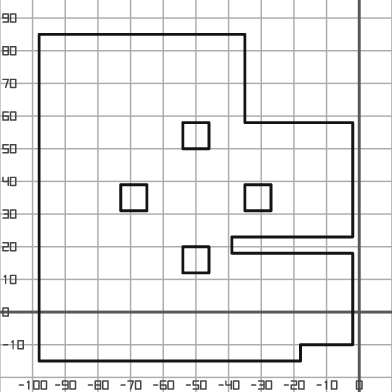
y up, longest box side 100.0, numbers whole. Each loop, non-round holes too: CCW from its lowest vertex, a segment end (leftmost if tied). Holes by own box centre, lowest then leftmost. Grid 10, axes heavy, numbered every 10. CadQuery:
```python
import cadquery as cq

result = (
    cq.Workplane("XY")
    .moveTo(-98.0, -15.0)
    .lineTo(-18.0, -15.0)
    .lineTo(-18.0, -10.0)
    .lineTo(-2.0, -10.0)
    .lineTo(-2.0, 18.0)
    .lineTo(-39.0, 18.0)
    .lineTo(-39.0, 23.0)
    .lineTo(-2.0, 23.0)
    .lineTo(-2.0, 58.0)
    .lineTo(-35.0, 58.0)
    .lineTo(-35.0, 85.0)
    .lineTo(-98.0, 85.0)
    .close()
    .moveTo(-54.0, 12.0)
    .lineTo(-46.0, 12.0)
    .lineTo(-46.0, 20.0)
    .lineTo(-54.0, 20.0)
    .close()
    .moveTo(-73.0, 31.0)
    .lineTo(-65.0, 31.0)
    .lineTo(-65.0, 39.0)
    .lineTo(-73.0, 39.0)
    .close()
    .moveTo(-35.0, 31.0)
    .lineTo(-27.0, 31.0)
    .lineTo(-27.0, 39.0)
    .lineTo(-35.0, 39.0)
    .close()
    .moveTo(-54.0, 50.0)
    .lineTo(-46.0, 50.0)
    .lineTo(-46.0, 58.0)
    .lineTo(-54.0, 58.0)
    .close()
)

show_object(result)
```